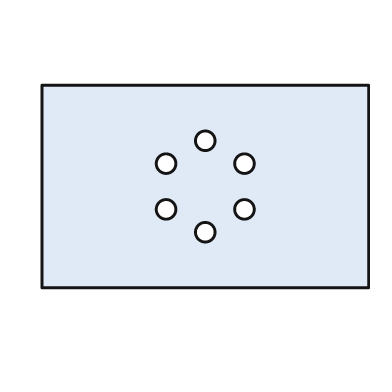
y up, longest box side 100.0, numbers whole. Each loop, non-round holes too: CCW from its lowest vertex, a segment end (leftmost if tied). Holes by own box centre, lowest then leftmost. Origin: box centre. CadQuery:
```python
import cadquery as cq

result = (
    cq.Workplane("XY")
    .moveTo(-50.0, -31.0)
    .lineTo(50.0, -31.0)
    .lineTo(50.0, 31.0)
    .lineTo(-50.0, 31.0)
    .close()
    .moveTo(0.0, -14.0)
    .circle(3.0)
    .moveTo(-12.0, -7.0)
    .circle(3.0)
    .moveTo(12.0, -7.0)
    .circle(3.0)
    .moveTo(-12.0, 7.0)
    .circle(3.0)
    .moveTo(12.0, 7.0)
    .circle(3.0)
    .moveTo(0.0, 14.0)
    .circle(3.0)
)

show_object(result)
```